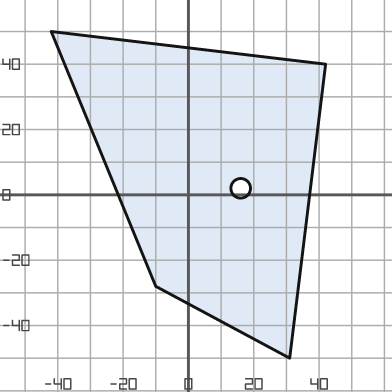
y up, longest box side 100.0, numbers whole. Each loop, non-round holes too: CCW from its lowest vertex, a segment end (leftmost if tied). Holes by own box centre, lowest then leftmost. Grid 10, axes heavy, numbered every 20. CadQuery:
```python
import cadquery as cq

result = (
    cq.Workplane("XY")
    .moveTo(31.0, -50.0)
    .lineTo(42.0, 40.0)
    .lineTo(-42.0, 50.0)
    .lineTo(-10.0, -28.0)
    .close()
    .moveTo(16.0, 2.0)
    .circle(3.0)
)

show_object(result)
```